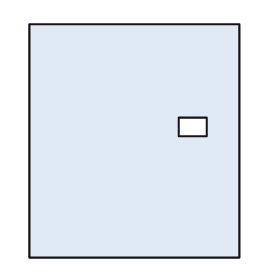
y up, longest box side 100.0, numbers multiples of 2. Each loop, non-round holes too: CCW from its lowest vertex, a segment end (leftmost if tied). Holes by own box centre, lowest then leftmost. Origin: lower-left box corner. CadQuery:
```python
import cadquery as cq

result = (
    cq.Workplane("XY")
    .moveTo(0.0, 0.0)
    .lineTo(90.0, 0.0)
    .lineTo(90.0, 100.0)
    .lineTo(0.0, 100.0)
    .close()
    .moveTo(64.0, 52.0)
    .lineTo(76.0, 52.0)
    .lineTo(76.0, 60.0)
    .lineTo(64.0, 60.0)
    .close()
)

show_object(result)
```